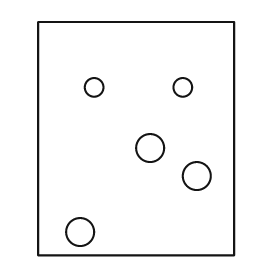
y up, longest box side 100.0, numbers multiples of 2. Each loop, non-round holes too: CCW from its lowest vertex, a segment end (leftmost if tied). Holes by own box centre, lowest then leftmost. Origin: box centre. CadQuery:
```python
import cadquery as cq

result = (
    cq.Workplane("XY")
    .moveTo(-42.0, -50.0)
    .lineTo(42.0, -50.0)
    .lineTo(42.0, 50.0)
    .lineTo(-42.0, 50.0)
    .close()
    .moveTo(-24.0, -40.0)
    .circle(6.0)
    .moveTo(26.0, -16.0)
    .circle(6.0)
    .moveTo(6.0, -4.0)
    .circle(6.0)
    .moveTo(-18.0, 22.0)
    .circle(4.0)
    .moveTo(20.0, 22.0)
    .circle(4.0)
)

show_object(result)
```